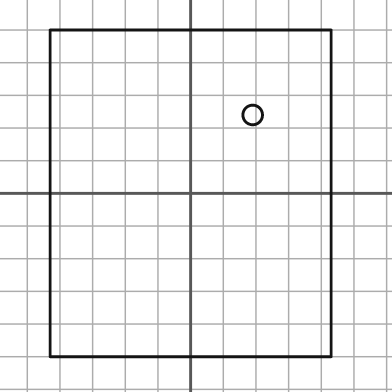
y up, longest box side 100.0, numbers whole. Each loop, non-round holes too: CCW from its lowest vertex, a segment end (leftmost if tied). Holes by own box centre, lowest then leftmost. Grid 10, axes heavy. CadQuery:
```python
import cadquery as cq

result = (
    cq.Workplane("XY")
    .moveTo(-43.0, -50.0)
    .lineTo(43.0, -50.0)
    .lineTo(43.0, 50.0)
    .lineTo(-43.0, 50.0)
    .close()
    .moveTo(19.0, 24.0)
    .circle(3.0)
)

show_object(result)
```